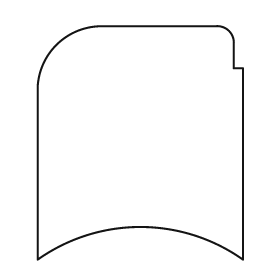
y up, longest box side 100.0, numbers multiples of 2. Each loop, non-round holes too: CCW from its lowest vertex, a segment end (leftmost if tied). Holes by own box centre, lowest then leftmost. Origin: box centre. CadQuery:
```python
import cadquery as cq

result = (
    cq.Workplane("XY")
    .moveTo(-44.0, -50.0)
    .threePointArc((0.0, -36.0), (44.0, -50.0))
    .lineTo(44.0, 32.0)
    .lineTo(40.0, 32.0)
    .lineTo(40.0, 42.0)
    .threePointArc((38.0, 48.0), (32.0, 50.0))
    .lineTo(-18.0, 50.0)
    .threePointArc((-36.0, 42.0), (-44.0, 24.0))
    .close()
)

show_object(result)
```